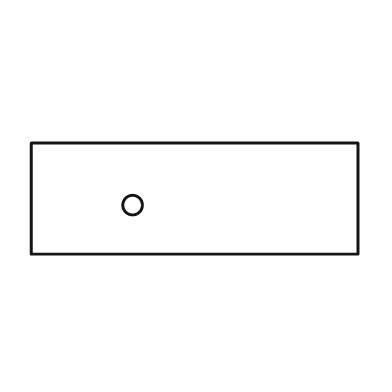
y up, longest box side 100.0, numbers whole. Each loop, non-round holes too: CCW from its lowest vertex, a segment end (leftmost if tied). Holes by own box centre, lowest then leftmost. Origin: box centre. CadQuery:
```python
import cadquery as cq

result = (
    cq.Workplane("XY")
    .moveTo(-50.0, -17.0)
    .lineTo(50.0, -17.0)
    .lineTo(50.0, 17.0)
    .lineTo(-50.0, 17.0)
    .close()
    .moveTo(-19.0, -2.0)
    .circle(3.0)
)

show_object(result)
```